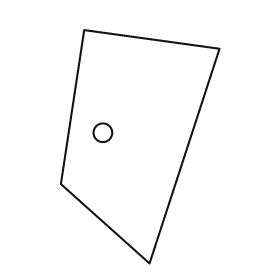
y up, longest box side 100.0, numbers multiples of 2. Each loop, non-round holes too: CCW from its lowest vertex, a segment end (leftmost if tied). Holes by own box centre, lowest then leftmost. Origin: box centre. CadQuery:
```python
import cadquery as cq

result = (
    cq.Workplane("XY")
    .moveTo(4.0, -50.0)
    .lineTo(34.0, 42.0)
    .lineTo(-24.0, 50.0)
    .lineTo(-34.0, -16.0)
    .close()
    .moveTo(-16.0, 6.0)
    .circle(4.0)
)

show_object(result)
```